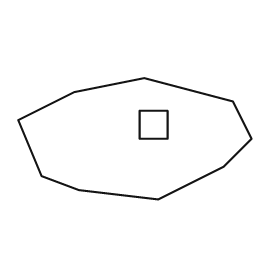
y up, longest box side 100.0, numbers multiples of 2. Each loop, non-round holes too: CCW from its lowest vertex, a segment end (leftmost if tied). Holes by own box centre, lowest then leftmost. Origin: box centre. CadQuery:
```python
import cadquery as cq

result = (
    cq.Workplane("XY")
    .moveTo(10.0, -26.0)
    .lineTo(38.0, -12.0)
    .lineTo(50.0, 0.0)
    .lineTo(42.0, 16.0)
    .lineTo(4.0, 26.0)
    .lineTo(-26.0, 20.0)
    .lineTo(-50.0, 8.0)
    .lineTo(-40.0, -16.0)
    .lineTo(-24.0, -22.0)
    .close()
    .moveTo(2.0, 0.0)
    .lineTo(14.0, 0.0)
    .lineTo(14.0, 12.0)
    .lineTo(2.0, 12.0)
    .close()
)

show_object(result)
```